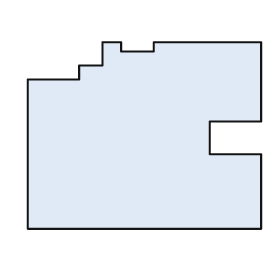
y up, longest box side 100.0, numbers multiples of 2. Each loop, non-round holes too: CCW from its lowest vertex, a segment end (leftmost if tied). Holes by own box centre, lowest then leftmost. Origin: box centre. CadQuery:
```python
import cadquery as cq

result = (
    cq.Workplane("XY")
    .moveTo(-50.0, -40.0)
    .lineTo(50.0, -40.0)
    .lineTo(50.0, -8.0)
    .lineTo(28.0, -8.0)
    .lineTo(28.0, 6.0)
    .lineTo(50.0, 6.0)
    .lineTo(50.0, 40.0)
    .lineTo(4.0, 40.0)
    .lineTo(4.0, 36.0)
    .lineTo(-10.0, 36.0)
    .lineTo(-10.0, 40.0)
    .lineTo(-18.0, 40.0)
    .lineTo(-18.0, 30.0)
    .lineTo(-28.0, 30.0)
    .lineTo(-28.0, 24.0)
    .lineTo(-50.0, 24.0)
    .close()
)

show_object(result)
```